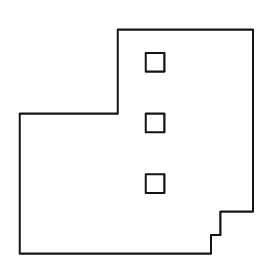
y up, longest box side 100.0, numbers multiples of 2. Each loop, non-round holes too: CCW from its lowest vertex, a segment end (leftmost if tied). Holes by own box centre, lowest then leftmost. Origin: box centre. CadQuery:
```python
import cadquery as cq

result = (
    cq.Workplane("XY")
    .moveTo(-50.0, -48.0)
    .lineTo(32.0, -48.0)
    .lineTo(32.0, -40.0)
    .lineTo(36.0, -40.0)
    .lineTo(36.0, -30.0)
    .lineTo(50.0, -30.0)
    .lineTo(50.0, 48.0)
    .lineTo(-8.0, 48.0)
    .lineTo(-8.0, 12.0)
    .lineTo(-50.0, 12.0)
    .close()
    .moveTo(4.0, -22.0)
    .lineTo(12.0, -22.0)
    .lineTo(12.0, -14.0)
    .lineTo(4.0, -14.0)
    .close()
    .moveTo(4.0, 4.0)
    .lineTo(12.0, 4.0)
    .lineTo(12.0, 12.0)
    .lineTo(4.0, 12.0)
    .close()
    .moveTo(4.0, 30.0)
    .lineTo(12.0, 30.0)
    .lineTo(12.0, 38.0)
    .lineTo(4.0, 38.0)
    .close()
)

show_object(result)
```